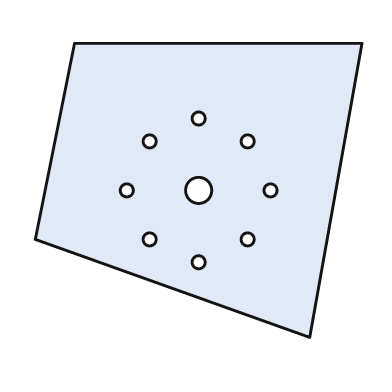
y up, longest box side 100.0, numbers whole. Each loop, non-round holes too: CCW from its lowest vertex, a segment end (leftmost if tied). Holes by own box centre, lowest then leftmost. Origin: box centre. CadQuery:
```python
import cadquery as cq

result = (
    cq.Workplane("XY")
    .moveTo(34.0, -45.0)
    .lineTo(50.0, 45.0)
    .lineTo(-38.0, 45.0)
    .lineTo(-50.0, -15.0)
    .close()
    .moveTo(0.0, -22.0)
    .circle(2.0)
    .moveTo(-15.0, -15.0)
    .circle(2.0)
    .moveTo(15.0, -15.0)
    .circle(2.0)
    .moveTo(-22.0, 0.0)
    .circle(2.0)
    .moveTo(0.0, 0.0)
    .circle(4.0)
    .moveTo(22.0, 0.0)
    .circle(2.0)
    .moveTo(-15.0, 15.0)
    .circle(2.0)
    .moveTo(15.0, 15.0)
    .circle(2.0)
    .moveTo(0.0, 22.0)
    .circle(2.0)
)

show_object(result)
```